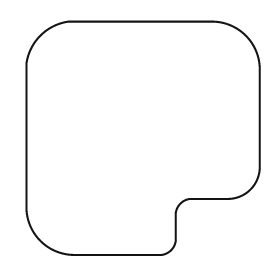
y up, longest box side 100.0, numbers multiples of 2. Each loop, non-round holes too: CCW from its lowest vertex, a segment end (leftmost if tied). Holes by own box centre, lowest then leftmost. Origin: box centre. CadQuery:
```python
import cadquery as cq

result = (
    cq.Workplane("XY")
    .moveTo(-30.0, -50.0)
    .lineTo(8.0, -50.0)
    .threePointArc((12.0, -48.0), (14.0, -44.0))
    .lineTo(14.0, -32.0)
    .threePointArc((16.0, -28.0), (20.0, -26.0))
    .lineTo(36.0, -26.0)
    .threePointArc((46.0, -22.0), (50.0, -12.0))
    .lineTo(50.0, 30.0)
    .threePointArc((44.0, 44.0), (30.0, 50.0))
    .lineTo(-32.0, 50.0)
    .threePointArc((-44.0, 44.0), (-50.0, 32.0))
    .lineTo(-50.0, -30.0)
    .threePointArc((-44.0, -44.0), (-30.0, -50.0))
    .close()
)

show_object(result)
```